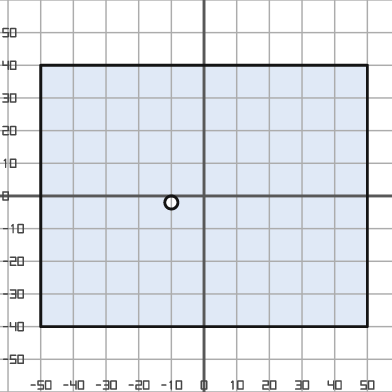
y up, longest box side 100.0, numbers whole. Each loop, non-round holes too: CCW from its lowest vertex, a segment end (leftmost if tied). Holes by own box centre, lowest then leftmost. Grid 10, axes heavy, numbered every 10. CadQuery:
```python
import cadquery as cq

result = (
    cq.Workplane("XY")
    .moveTo(-50.0, -40.0)
    .lineTo(50.0, -40.0)
    .lineTo(50.0, 40.0)
    .lineTo(-50.0, 40.0)
    .close()
    .moveTo(-10.0, -2.0)
    .circle(2.0)
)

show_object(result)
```